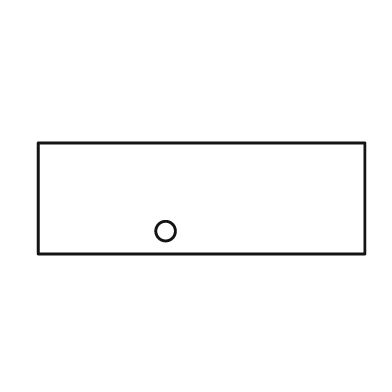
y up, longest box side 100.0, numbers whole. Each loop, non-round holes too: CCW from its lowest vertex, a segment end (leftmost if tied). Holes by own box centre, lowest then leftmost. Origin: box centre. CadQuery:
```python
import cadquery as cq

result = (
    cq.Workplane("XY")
    .moveTo(-50.0, -17.0)
    .lineTo(50.0, -17.0)
    .lineTo(50.0, 17.0)
    .lineTo(-50.0, 17.0)
    .close()
    .moveTo(-11.0, -10.0)
    .circle(3.0)
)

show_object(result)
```